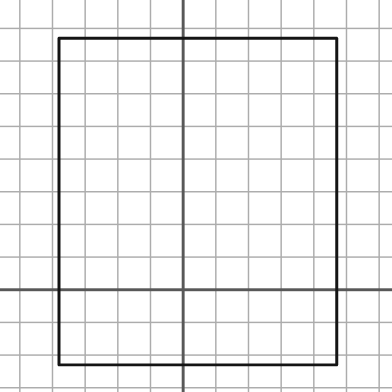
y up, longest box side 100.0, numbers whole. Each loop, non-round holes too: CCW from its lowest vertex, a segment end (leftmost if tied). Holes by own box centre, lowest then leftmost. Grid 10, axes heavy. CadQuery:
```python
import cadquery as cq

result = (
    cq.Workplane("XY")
    .moveTo(-38.0, -23.0)
    .lineTo(47.0, -23.0)
    .lineTo(47.0, 77.0)
    .lineTo(-38.0, 77.0)
    .close()
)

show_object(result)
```